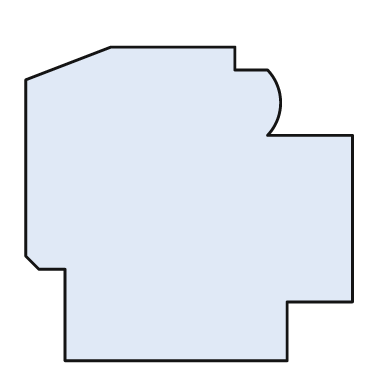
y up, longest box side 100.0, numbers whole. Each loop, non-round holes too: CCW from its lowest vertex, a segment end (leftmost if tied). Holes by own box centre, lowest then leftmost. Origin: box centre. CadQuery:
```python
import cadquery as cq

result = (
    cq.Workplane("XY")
    .moveTo(-38.0, -48.0)
    .lineTo(30.0, -48.0)
    .lineTo(30.0, -30.0)
    .lineTo(50.0, -30.0)
    .lineTo(50.0, 21.0)
    .lineTo(24.0, 21.0)
    .threePointArc((28.0, 31.0), (24.0, 41.0))
    .lineTo(14.0, 41.0)
    .lineTo(14.0, 48.0)
    .lineTo(-24.0, 48.0)
    .lineTo(-50.0, 38.0)
    .lineTo(-50.0, -16.0)
    .lineTo(-46.0, -20.0)
    .lineTo(-38.0, -20.0)
    .close()
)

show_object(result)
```